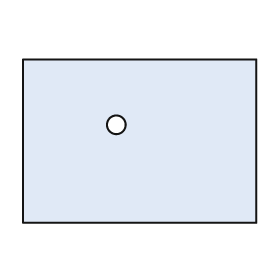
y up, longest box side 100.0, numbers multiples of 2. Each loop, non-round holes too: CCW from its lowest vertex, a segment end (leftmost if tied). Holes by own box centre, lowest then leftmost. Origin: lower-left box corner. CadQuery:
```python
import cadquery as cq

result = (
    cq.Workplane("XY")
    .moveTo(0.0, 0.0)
    .lineTo(100.0, 0.0)
    .lineTo(100.0, 70.0)
    .lineTo(0.0, 70.0)
    .close()
    .moveTo(40.0, 42.0)
    .circle(4.0)
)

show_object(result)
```